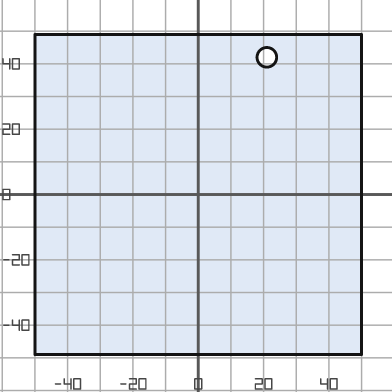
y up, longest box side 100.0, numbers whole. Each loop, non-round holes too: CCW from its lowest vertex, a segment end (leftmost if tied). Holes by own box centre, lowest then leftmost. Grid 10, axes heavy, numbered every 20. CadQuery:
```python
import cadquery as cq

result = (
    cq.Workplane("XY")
    .moveTo(-50.0, -49.0)
    .lineTo(50.0, -49.0)
    .lineTo(50.0, 49.0)
    .lineTo(-50.0, 49.0)
    .close()
    .moveTo(21.0, 42.0)
    .circle(3.0)
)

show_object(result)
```